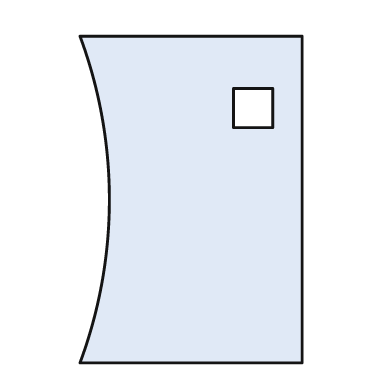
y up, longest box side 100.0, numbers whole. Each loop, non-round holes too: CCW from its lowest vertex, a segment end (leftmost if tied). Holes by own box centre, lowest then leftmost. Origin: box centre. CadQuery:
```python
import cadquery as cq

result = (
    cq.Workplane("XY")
    .moveTo(-34.0, -50.0)
    .lineTo(34.0, -50.0)
    .lineTo(34.0, 50.0)
    .lineTo(-34.0, 50.0)
    .threePointArc((-25.0, 0.0), (-34.0, -50.0))
    .close()
    .moveTo(13.0, 22.0)
    .lineTo(25.0, 22.0)
    .lineTo(25.0, 34.0)
    .lineTo(13.0, 34.0)
    .close()
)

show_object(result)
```